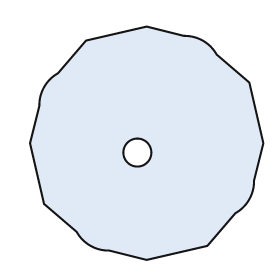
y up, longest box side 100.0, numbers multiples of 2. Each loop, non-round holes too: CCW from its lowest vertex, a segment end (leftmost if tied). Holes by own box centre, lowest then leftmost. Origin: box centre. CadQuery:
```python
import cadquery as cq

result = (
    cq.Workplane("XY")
    .moveTo(0.0, -50.0)
    .lineTo(26.0, -44.0)
    .lineTo(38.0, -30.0)
    .threePointArc((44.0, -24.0), (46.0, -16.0))
    .lineTo(50.0, 0.0)
    .lineTo(44.0, 26.0)
    .lineTo(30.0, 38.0)
    .threePointArc((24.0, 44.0), (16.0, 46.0))
    .lineTo(0.0, 50.0)
    .lineTo(-26.0, 44.0)
    .lineTo(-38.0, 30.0)
    .threePointArc((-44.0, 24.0), (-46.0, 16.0))
    .lineTo(-50.0, 0.0)
    .lineTo(-44.0, -26.0)
    .lineTo(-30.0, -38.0)
    .threePointArc((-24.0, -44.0), (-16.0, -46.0))
    .close()
    .moveTo(-4.0, -4.0)
    .circle(6.0)
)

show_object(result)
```